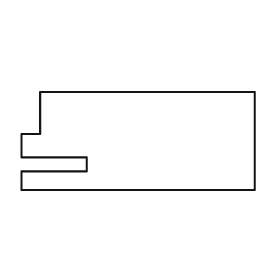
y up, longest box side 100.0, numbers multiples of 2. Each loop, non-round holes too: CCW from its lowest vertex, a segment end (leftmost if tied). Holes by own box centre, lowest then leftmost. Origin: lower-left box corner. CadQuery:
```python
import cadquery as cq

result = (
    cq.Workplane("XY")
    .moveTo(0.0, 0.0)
    .lineTo(100.0, 0.0)
    .lineTo(100.0, 42.0)
    .lineTo(8.0, 42.0)
    .lineTo(8.0, 24.0)
    .lineTo(0.0, 24.0)
    .lineTo(0.0, 14.0)
    .lineTo(28.0, 14.0)
    .lineTo(28.0, 8.0)
    .lineTo(0.0, 8.0)
    .close()
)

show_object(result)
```